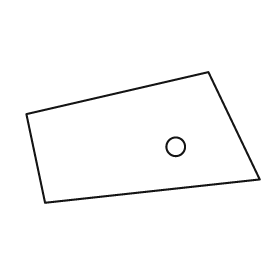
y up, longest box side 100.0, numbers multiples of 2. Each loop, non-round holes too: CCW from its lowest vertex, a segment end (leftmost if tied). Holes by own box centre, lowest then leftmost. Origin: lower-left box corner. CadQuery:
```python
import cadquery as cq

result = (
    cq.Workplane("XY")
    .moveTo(8.0, 0.0)
    .lineTo(100.0, 10.0)
    .lineTo(78.0, 56.0)
    .lineTo(0.0, 38.0)
    .close()
    .moveTo(64.0, 24.0)
    .circle(4.0)
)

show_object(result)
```